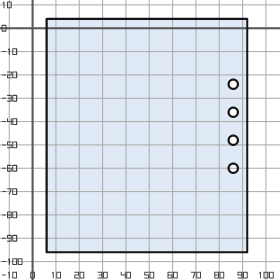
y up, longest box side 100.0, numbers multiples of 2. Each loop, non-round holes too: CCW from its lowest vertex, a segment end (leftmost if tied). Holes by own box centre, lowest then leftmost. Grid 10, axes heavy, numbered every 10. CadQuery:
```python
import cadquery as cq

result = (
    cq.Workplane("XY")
    .moveTo(6.0, -96.0)
    .lineTo(92.0, -96.0)
    .lineTo(92.0, 4.0)
    .lineTo(6.0, 4.0)
    .close()
    .moveTo(86.0, -60.0)
    .circle(2.0)
    .moveTo(86.0, -48.0)
    .circle(2.0)
    .moveTo(86.0, -36.0)
    .circle(2.0)
    .moveTo(86.0, -24.0)
    .circle(2.0)
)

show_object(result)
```